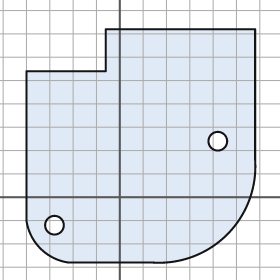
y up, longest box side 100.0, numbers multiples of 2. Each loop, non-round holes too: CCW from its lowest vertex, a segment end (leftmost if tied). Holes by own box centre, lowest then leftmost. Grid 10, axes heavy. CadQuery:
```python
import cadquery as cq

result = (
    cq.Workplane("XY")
    .moveTo(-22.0, -28.0)
    .lineTo(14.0, -28.0)
    .threePointArc((46.0, -16.0), (58.0, 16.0))
    .lineTo(58.0, 72.0)
    .lineTo(-6.0, 72.0)
    .lineTo(-6.0, 54.0)
    .lineTo(-40.0, 54.0)
    .lineTo(-40.0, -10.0)
    .threePointArc((-34.0, -22.0), (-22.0, -28.0))
    .close()
    .moveTo(-28.0, -12.0)
    .circle(4.0)
    .moveTo(42.0, 24.0)
    .circle(4.0)
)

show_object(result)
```